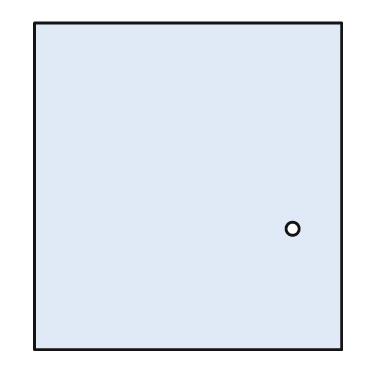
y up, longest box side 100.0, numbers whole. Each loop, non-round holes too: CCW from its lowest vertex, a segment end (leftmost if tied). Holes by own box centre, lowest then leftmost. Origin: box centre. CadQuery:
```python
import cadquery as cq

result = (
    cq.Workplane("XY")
    .moveTo(-47.0, -50.0)
    .lineTo(47.0, -50.0)
    .lineTo(47.0, 50.0)
    .lineTo(-47.0, 50.0)
    .close()
    .moveTo(32.0, -13.0)
    .circle(2.0)
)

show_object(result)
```